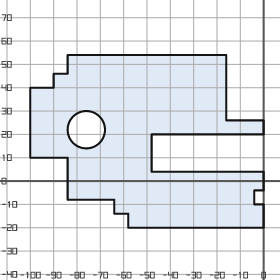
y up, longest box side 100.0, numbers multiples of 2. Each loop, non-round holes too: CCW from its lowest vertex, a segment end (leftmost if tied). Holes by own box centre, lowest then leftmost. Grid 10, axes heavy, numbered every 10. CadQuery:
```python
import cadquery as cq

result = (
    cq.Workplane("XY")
    .moveTo(-58.0, -20.0)
    .lineTo(0.0, -20.0)
    .lineTo(0.0, -10.0)
    .lineTo(-4.0, -10.0)
    .lineTo(-4.0, -4.0)
    .lineTo(0.0, -4.0)
    .lineTo(0.0, 4.0)
    .lineTo(-48.0, 4.0)
    .lineTo(-48.0, 20.0)
    .lineTo(0.0, 20.0)
    .lineTo(0.0, 26.0)
    .lineTo(-16.0, 26.0)
    .lineTo(-16.0, 54.0)
    .lineTo(-84.0, 54.0)
    .lineTo(-84.0, 46.0)
    .lineTo(-90.0, 46.0)
    .lineTo(-90.0, 40.0)
    .lineTo(-100.0, 40.0)
    .lineTo(-100.0, 10.0)
    .lineTo(-84.0, 10.0)
    .lineTo(-84.0, -8.0)
    .lineTo(-64.0, -8.0)
    .lineTo(-64.0, -14.0)
    .lineTo(-58.0, -14.0)
    .close()
    .moveTo(-76.0, 22.0)
    .circle(8.0)
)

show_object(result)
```